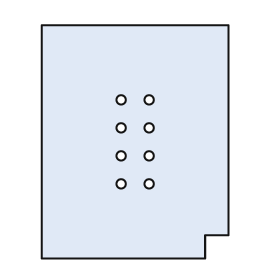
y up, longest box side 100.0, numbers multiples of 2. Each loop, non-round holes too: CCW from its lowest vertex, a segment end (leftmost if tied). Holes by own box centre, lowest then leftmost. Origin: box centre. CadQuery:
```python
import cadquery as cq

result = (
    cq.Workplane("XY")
    .moveTo(-40.0, -50.0)
    .lineTo(30.0, -50.0)
    .lineTo(30.0, -40.0)
    .lineTo(40.0, -40.0)
    .lineTo(40.0, 50.0)
    .lineTo(-40.0, 50.0)
    .close()
    .moveTo(-6.0, -18.0)
    .circle(2.0)
    .moveTo(6.0, -18.0)
    .circle(2.0)
    .moveTo(-6.0, -6.0)
    .circle(2.0)
    .moveTo(6.0, -6.0)
    .circle(2.0)
    .moveTo(-6.0, 6.0)
    .circle(2.0)
    .moveTo(6.0, 6.0)
    .circle(2.0)
    .moveTo(-6.0, 18.0)
    .circle(2.0)
    .moveTo(6.0, 18.0)
    .circle(2.0)
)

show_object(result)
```